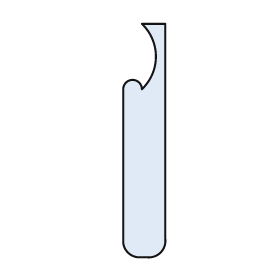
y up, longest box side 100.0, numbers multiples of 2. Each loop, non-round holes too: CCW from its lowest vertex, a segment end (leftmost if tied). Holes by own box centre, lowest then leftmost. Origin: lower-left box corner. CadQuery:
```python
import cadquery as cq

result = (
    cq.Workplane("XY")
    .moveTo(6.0, 0.0)
    .lineTo(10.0, 0.0)
    .threePointArc((16.0, 2.0), (18.0, 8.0))
    .lineTo(18.0, 100.0)
    .lineTo(8.0, 100.0)
    .threePointArc((14.0, 86.0), (8.0, 72.0))
    .threePointArc((4.0, 76.0), (0.0, 72.0))
    .lineTo(0.0, 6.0)
    .threePointArc((2.0, 2.0), (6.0, 0.0))
    .close()
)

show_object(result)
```